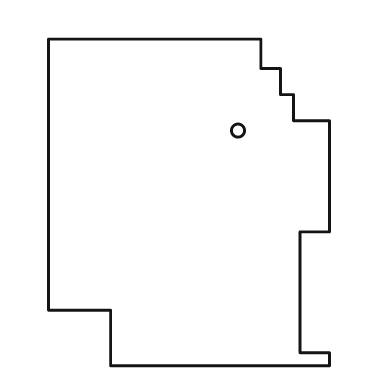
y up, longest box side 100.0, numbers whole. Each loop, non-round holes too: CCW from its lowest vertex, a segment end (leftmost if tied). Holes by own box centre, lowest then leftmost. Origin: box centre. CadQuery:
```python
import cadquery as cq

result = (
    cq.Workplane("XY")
    .moveTo(-24.0, -50.0)
    .lineTo(43.0, -50.0)
    .lineTo(43.0, -46.0)
    .lineTo(34.0, -46.0)
    .lineTo(34.0, -9.0)
    .lineTo(43.0, -9.0)
    .lineTo(43.0, 25.0)
    .lineTo(32.0, 25.0)
    .lineTo(32.0, 33.0)
    .lineTo(28.0, 33.0)
    .lineTo(28.0, 41.0)
    .lineTo(22.0, 41.0)
    .lineTo(22.0, 50.0)
    .lineTo(-43.0, 50.0)
    .lineTo(-43.0, -33.0)
    .lineTo(-24.0, -33.0)
    .close()
    .moveTo(15.0, 22.0)
    .circle(2.0)
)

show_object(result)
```